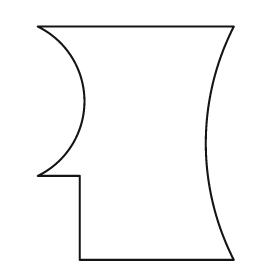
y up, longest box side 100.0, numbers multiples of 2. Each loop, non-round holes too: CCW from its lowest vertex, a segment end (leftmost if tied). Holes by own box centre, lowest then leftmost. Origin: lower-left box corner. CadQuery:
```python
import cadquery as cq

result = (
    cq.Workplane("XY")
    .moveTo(18.0, 0.0)
    .lineTo(84.0, 0.0)
    .threePointArc((72.0, 50.0), (84.0, 100.0))
    .lineTo(0.0, 100.0)
    .threePointArc((20.0, 68.0), (0.0, 36.0))
    .lineTo(18.0, 36.0)
    .close()
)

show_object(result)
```